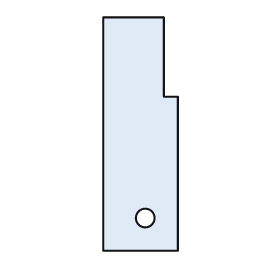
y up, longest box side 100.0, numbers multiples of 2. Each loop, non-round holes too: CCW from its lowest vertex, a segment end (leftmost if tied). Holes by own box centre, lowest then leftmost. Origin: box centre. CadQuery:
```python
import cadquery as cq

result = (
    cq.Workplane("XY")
    .moveTo(-16.0, -50.0)
    .lineTo(16.0, -50.0)
    .lineTo(16.0, 16.0)
    .lineTo(10.0, 16.0)
    .lineTo(10.0, 50.0)
    .lineTo(-16.0, 50.0)
    .close()
    .moveTo(2.0, -36.0)
    .circle(4.0)
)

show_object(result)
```